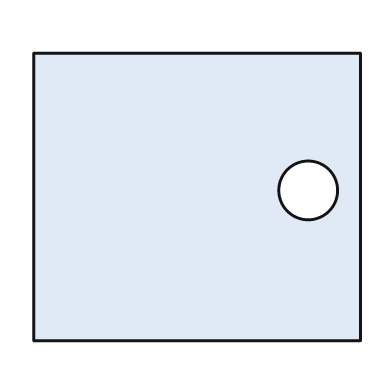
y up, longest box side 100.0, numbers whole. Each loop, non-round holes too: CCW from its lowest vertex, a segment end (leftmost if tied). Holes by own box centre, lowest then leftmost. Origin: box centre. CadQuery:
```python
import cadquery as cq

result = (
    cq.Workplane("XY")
    .moveTo(-50.0, -44.0)
    .lineTo(50.0, -44.0)
    .lineTo(50.0, 44.0)
    .lineTo(-50.0, 44.0)
    .close()
    .moveTo(34.0, 2.0)
    .circle(9.0)
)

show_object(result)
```